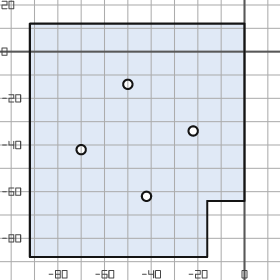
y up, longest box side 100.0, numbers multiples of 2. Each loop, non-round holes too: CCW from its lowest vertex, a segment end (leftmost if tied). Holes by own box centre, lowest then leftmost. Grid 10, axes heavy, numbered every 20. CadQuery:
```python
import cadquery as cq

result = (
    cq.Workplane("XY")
    .moveTo(-92.0, -88.0)
    .lineTo(-16.0, -88.0)
    .lineTo(-16.0, -64.0)
    .lineTo(0.0, -64.0)
    .lineTo(0.0, 12.0)
    .lineTo(-92.0, 12.0)
    .close()
    .moveTo(-42.0, -62.0)
    .circle(2.0)
    .moveTo(-70.0, -42.0)
    .circle(2.0)
    .moveTo(-22.0, -34.0)
    .circle(2.0)
    .moveTo(-50.0, -14.0)
    .circle(2.0)
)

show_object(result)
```